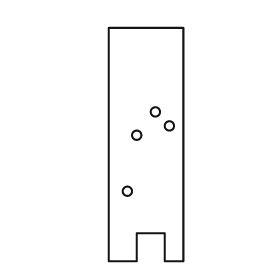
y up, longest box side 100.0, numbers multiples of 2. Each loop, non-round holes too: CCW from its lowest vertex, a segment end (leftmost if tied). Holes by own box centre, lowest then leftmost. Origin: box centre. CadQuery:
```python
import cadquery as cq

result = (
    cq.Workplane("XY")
    .moveTo(-16.0, -50.0)
    .lineTo(-4.0, -50.0)
    .lineTo(-4.0, -38.0)
    .lineTo(8.0, -38.0)
    .lineTo(8.0, -50.0)
    .lineTo(16.0, -50.0)
    .lineTo(16.0, 50.0)
    .lineTo(-16.0, 50.0)
    .close()
    .moveTo(-8.0, -20.0)
    .circle(2.0)
    .moveTo(-4.0, 4.0)
    .circle(2.0)
    .moveTo(10.0, 8.0)
    .circle(2.0)
    .moveTo(4.0, 14.0)
    .circle(2.0)
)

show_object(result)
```